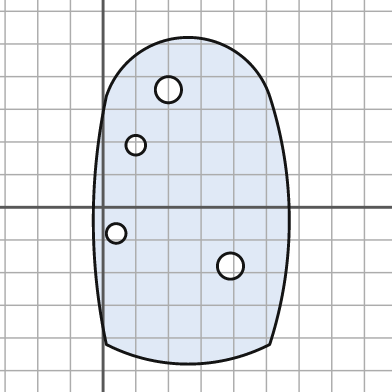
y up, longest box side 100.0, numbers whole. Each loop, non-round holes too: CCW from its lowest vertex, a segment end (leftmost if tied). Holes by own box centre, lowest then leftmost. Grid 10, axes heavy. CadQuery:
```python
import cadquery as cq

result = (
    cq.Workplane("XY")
    .moveTo(1.0, -42.0)
    .threePointArc((26.0, -48.0), (51.0, -42.0))
    .threePointArc((57.0, -4.0), (51.0, 34.0))
    .threePointArc((26.0, 52.0), (1.0, 34.0))
    .threePointArc((-3.0, -4.0), (1.0, -42.0))
    .close()
    .moveTo(39.0, -18.0)
    .circle(4.0)
    .moveTo(4.0, -8.0)
    .circle(3.0)
    .moveTo(10.0, 19.0)
    .circle(3.0)
    .moveTo(20.0, 36.0)
    .circle(4.0)
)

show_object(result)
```